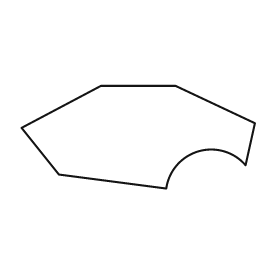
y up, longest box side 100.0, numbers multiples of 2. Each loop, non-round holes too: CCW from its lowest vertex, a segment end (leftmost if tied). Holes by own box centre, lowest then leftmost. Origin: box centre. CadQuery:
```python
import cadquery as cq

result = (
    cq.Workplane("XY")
    .moveTo(12.0, -22.0)
    .threePointArc((26.0, -6.0), (46.0, -12.0))
    .lineTo(50.0, 6.0)
    .lineTo(16.0, 22.0)
    .lineTo(-16.0, 22.0)
    .lineTo(-50.0, 4.0)
    .lineTo(-34.0, -16.0)
    .close()
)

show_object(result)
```